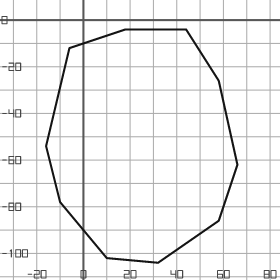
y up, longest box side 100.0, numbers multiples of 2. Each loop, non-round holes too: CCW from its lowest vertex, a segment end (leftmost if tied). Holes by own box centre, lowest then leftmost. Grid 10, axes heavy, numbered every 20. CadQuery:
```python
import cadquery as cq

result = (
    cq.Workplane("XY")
    .moveTo(32.0, -104.0)
    .lineTo(58.0, -86.0)
    .lineTo(66.0, -62.0)
    .lineTo(58.0, -26.0)
    .lineTo(44.0, -4.0)
    .lineTo(18.0, -4.0)
    .lineTo(-6.0, -12.0)
    .lineTo(-16.0, -54.0)
    .lineTo(-10.0, -78.0)
    .lineTo(10.0, -102.0)
    .close()
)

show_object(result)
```